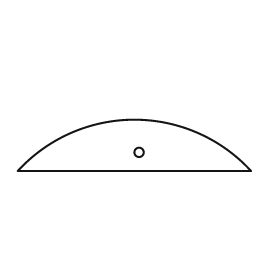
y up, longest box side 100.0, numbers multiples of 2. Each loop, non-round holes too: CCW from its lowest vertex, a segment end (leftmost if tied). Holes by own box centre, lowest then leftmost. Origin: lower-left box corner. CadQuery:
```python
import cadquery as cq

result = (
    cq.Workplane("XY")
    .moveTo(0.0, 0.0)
    .lineTo(100.0, 0.0)
    .threePointArc((50.0, 22.0), (0.0, 0.0))
    .close()
    .moveTo(52.0, 8.0)
    .circle(2.0)
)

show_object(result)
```